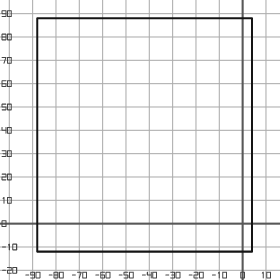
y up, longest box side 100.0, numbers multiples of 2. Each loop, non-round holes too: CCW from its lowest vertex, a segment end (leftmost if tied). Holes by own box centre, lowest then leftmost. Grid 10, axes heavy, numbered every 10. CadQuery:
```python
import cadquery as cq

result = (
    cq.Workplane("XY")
    .moveTo(-88.0, -12.0)
    .lineTo(4.0, -12.0)
    .lineTo(4.0, 88.0)
    .lineTo(-88.0, 88.0)
    .close()
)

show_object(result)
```